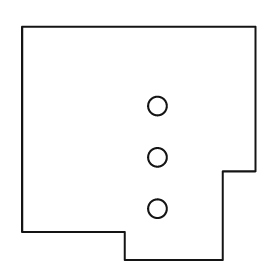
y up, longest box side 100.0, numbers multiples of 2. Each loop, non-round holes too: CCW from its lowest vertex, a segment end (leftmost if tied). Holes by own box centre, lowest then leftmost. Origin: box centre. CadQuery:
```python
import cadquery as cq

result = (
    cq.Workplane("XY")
    .moveTo(-6.0, -50.0)
    .lineTo(36.0, -50.0)
    .lineTo(36.0, -12.0)
    .lineTo(50.0, -12.0)
    .lineTo(50.0, 50.0)
    .lineTo(-50.0, 50.0)
    .lineTo(-50.0, -38.0)
    .lineTo(-6.0, -38.0)
    .close()
    .moveTo(8.0, -28.0)
    .circle(4.0)
    .moveTo(8.0, -6.0)
    .circle(4.0)
    .moveTo(8.0, 16.0)
    .circle(4.0)
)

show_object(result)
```